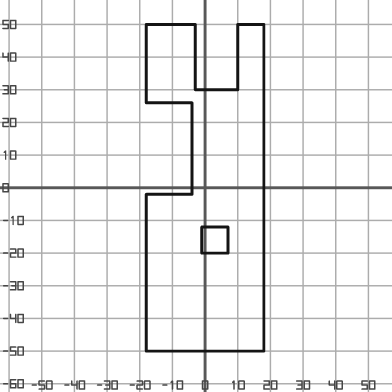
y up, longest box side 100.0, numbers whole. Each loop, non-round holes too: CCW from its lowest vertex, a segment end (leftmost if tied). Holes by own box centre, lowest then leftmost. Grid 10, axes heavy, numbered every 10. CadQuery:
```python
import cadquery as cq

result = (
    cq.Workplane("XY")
    .moveTo(-18.0, -50.0)
    .lineTo(18.0, -50.0)
    .lineTo(18.0, 50.0)
    .lineTo(10.0, 50.0)
    .lineTo(10.0, 30.0)
    .lineTo(-3.0, 30.0)
    .lineTo(-3.0, 50.0)
    .lineTo(-18.0, 50.0)
    .lineTo(-18.0, 26.0)
    .lineTo(-4.0, 26.0)
    .lineTo(-4.0, -2.0)
    .lineTo(-18.0, -2.0)
    .close()
    .moveTo(-1.0, -20.0)
    .lineTo(7.0, -20.0)
    .lineTo(7.0, -12.0)
    .lineTo(-1.0, -12.0)
    .close()
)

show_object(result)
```